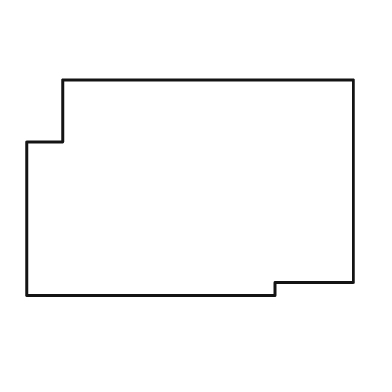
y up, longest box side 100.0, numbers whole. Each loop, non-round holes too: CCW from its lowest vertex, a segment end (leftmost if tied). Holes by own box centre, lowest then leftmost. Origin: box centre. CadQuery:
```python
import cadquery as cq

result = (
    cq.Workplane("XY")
    .moveTo(-50.0, -33.0)
    .lineTo(26.0, -33.0)
    .lineTo(26.0, -29.0)
    .lineTo(50.0, -29.0)
    .lineTo(50.0, 33.0)
    .lineTo(-39.0, 33.0)
    .lineTo(-39.0, 14.0)
    .lineTo(-50.0, 14.0)
    .close()
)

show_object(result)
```